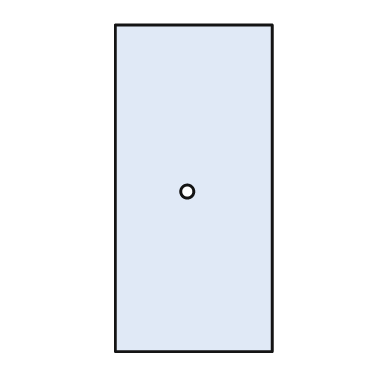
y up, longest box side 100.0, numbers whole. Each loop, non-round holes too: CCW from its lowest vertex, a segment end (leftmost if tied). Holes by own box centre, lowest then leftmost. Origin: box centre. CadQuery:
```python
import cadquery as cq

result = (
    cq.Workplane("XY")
    .moveTo(-24.0, -50.0)
    .lineTo(24.0, -50.0)
    .lineTo(24.0, 50.0)
    .lineTo(-24.0, 50.0)
    .close()
    .moveTo(-2.0, -1.0)
    .circle(2.0)
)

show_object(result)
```